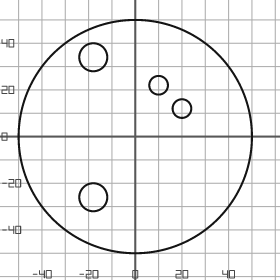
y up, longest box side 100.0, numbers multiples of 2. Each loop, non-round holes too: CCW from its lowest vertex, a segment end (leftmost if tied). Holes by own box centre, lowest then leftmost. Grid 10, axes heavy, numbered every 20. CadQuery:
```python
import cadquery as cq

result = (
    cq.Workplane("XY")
    .moveTo(0.0, 0.0)
    .circle(50.0)
    .moveTo(-18.0, -26.0)
    .circle(6.0)
    .moveTo(20.0, 12.0)
    .circle(4.0)
    .moveTo(10.0, 22.0)
    .circle(4.0)
    .moveTo(-18.0, 34.0)
    .circle(6.0)
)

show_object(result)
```